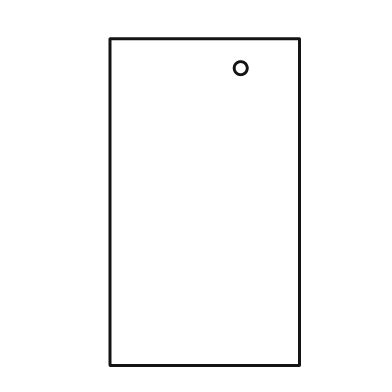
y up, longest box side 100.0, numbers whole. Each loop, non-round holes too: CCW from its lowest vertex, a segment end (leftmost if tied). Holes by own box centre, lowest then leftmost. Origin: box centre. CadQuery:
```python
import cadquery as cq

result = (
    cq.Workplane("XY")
    .moveTo(-29.0, -50.0)
    .lineTo(29.0, -50.0)
    .lineTo(29.0, 50.0)
    .lineTo(-29.0, 50.0)
    .close()
    .moveTo(11.0, 41.0)
    .circle(2.0)
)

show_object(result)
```